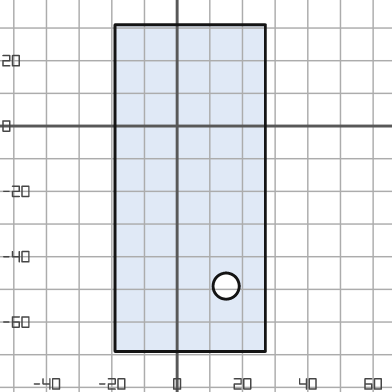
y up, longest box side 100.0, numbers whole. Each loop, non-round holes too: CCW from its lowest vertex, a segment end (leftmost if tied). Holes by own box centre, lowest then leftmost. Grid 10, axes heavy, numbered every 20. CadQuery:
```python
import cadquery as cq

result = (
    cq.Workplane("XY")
    .moveTo(-19.0, -69.0)
    .lineTo(27.0, -69.0)
    .lineTo(27.0, 31.0)
    .lineTo(-19.0, 31.0)
    .close()
    .moveTo(15.0, -49.0)
    .circle(4.0)
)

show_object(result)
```